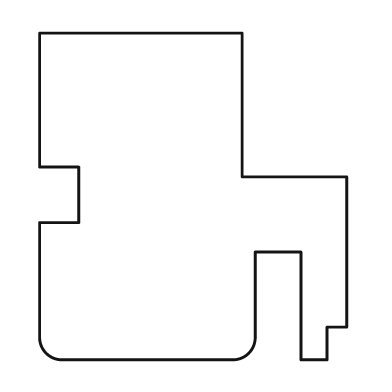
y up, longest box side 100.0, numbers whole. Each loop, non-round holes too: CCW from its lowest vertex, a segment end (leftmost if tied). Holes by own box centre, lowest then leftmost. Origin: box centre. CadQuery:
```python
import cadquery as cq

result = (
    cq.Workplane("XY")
    .moveTo(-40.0, -50.0)
    .lineTo(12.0, -50.0)
    .threePointArc((17.0, -48.0), (19.0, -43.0))
    .lineTo(19.0, -17.0)
    .lineTo(33.0, -17.0)
    .lineTo(33.0, -50.0)
    .lineTo(41.0, -50.0)
    .lineTo(41.0, -40.0)
    .lineTo(47.0, -40.0)
    .lineTo(47.0, 6.0)
    .lineTo(15.0, 6.0)
    .lineTo(15.0, 50.0)
    .lineTo(-47.0, 50.0)
    .lineTo(-47.0, 9.0)
    .lineTo(-35.0, 9.0)
    .lineTo(-35.0, -8.0)
    .lineTo(-47.0, -8.0)
    .lineTo(-47.0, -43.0)
    .threePointArc((-45.0, -48.0), (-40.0, -50.0))
    .close()
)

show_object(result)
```